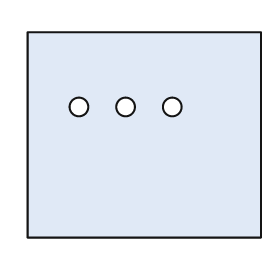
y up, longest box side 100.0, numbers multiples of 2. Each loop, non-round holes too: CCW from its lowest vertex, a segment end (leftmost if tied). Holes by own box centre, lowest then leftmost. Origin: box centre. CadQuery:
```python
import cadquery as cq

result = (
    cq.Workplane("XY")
    .moveTo(-50.0, -44.0)
    .lineTo(50.0, -44.0)
    .lineTo(50.0, 44.0)
    .lineTo(-50.0, 44.0)
    .close()
    .moveTo(-28.0, 12.0)
    .circle(4.0)
    .moveTo(-8.0, 12.0)
    .circle(4.0)
    .moveTo(12.0, 12.0)
    .circle(4.0)
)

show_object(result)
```